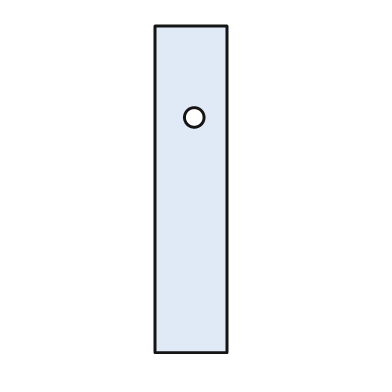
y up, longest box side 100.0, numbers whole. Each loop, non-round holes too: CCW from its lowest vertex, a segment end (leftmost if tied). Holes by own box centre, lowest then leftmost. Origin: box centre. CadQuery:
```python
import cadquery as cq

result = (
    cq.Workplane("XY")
    .moveTo(-11.0, -50.0)
    .lineTo(11.0, -50.0)
    .lineTo(11.0, 50.0)
    .lineTo(-11.0, 50.0)
    .close()
    .moveTo(1.0, 22.0)
    .circle(3.0)
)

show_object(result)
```